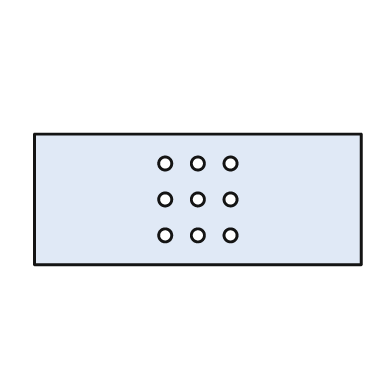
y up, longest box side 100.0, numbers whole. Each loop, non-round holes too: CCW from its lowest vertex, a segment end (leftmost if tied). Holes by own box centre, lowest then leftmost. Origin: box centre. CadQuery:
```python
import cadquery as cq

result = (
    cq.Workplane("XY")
    .moveTo(-50.0, -20.0)
    .lineTo(50.0, -20.0)
    .lineTo(50.0, 20.0)
    .lineTo(-50.0, 20.0)
    .close()
    .moveTo(-10.0, -11.0)
    .circle(2.0)
    .moveTo(0.0, -11.0)
    .circle(2.0)
    .moveTo(10.0, -11.0)
    .circle(2.0)
    .moveTo(-10.0, 0.0)
    .circle(2.0)
    .moveTo(0.0, 0.0)
    .circle(2.0)
    .moveTo(10.0, 0.0)
    .circle(2.0)
    .moveTo(-10.0, 11.0)
    .circle(2.0)
    .moveTo(0.0, 11.0)
    .circle(2.0)
    .moveTo(10.0, 11.0)
    .circle(2.0)
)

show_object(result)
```